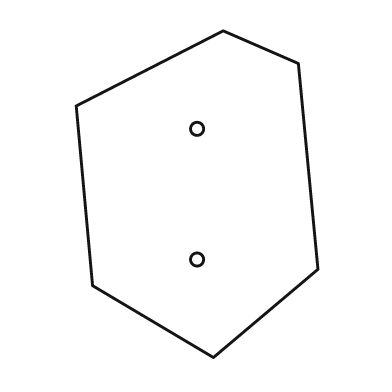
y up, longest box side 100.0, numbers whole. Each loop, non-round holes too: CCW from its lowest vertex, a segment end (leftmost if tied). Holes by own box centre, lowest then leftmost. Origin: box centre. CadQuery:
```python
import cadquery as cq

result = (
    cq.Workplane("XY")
    .moveTo(5.0, -50.0)
    .lineTo(37.0, -23.0)
    .lineTo(31.0, 40.0)
    .lineTo(8.0, 50.0)
    .lineTo(-37.0, 27.0)
    .lineTo(-32.0, -28.0)
    .close()
    .moveTo(0.0, -20.0)
    .circle(2.0)
    .moveTo(0.0, 20.0)
    .circle(2.0)
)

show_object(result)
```